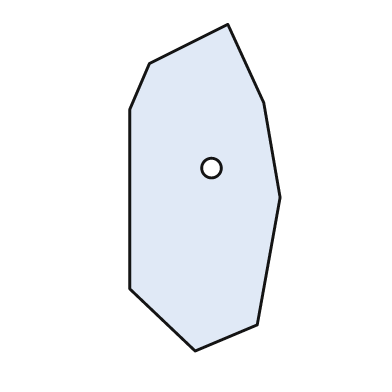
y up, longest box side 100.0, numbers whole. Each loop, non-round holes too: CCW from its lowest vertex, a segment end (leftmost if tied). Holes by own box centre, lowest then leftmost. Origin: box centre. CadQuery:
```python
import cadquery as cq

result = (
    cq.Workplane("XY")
    .moveTo(-3.0, -50.0)
    .lineTo(16.0, -42.0)
    .lineTo(23.0, -3.0)
    .lineTo(18.0, 26.0)
    .lineTo(7.0, 50.0)
    .lineTo(-17.0, 38.0)
    .lineTo(-23.0, 24.0)
    .lineTo(-23.0, -31.0)
    .close()
    .moveTo(2.0, 6.0)
    .circle(3.0)
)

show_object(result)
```